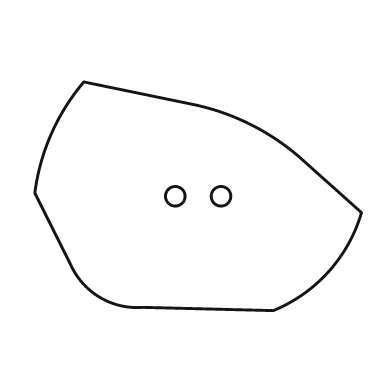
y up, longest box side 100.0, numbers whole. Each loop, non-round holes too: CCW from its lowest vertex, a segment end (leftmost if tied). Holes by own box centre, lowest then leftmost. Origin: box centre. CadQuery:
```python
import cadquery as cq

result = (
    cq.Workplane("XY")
    .moveTo(23.0, -35.0)
    .threePointArc((40.0, -23.0), (50.0, -5.0))
    .lineTo(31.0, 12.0)
    .threePointArc((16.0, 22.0), (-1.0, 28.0))
    .lineTo(-35.0, 35.0)
    .threePointArc((-45.0, 19.0), (-50.0, 1.0))
    .lineTo(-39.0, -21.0)
    .threePointArc((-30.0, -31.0), (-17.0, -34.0))
    .close()
    .moveTo(-7.0, 0.0)
    .circle(3.0)
    .moveTo(7.0, 0.0)
    .circle(3.0)
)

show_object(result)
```